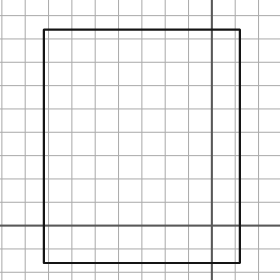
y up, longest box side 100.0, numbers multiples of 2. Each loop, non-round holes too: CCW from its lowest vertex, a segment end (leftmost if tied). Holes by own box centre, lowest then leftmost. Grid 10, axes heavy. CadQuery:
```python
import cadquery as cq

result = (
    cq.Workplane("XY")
    .moveTo(-72.0, -16.0)
    .lineTo(12.0, -16.0)
    .lineTo(12.0, 84.0)
    .lineTo(-72.0, 84.0)
    .close()
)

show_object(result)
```